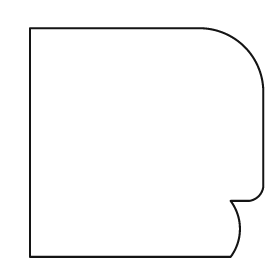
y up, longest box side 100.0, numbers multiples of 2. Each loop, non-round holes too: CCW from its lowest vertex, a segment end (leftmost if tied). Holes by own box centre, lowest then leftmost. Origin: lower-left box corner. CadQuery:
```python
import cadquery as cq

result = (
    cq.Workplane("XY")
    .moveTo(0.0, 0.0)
    .lineTo(86.0, 0.0)
    .threePointArc((90.0, 12.0), (86.0, 24.0))
    .lineTo(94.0, 24.0)
    .threePointArc((98.0, 26.0), (100.0, 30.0))
    .lineTo(100.0, 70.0)
    .threePointArc((92.0, 90.0), (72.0, 98.0))
    .lineTo(0.0, 98.0)
    .close()
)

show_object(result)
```